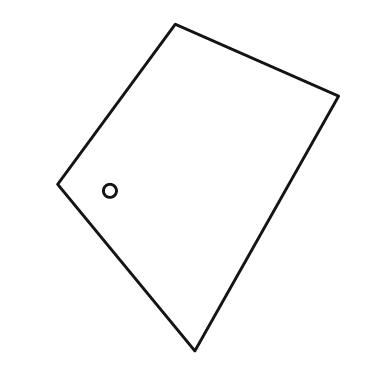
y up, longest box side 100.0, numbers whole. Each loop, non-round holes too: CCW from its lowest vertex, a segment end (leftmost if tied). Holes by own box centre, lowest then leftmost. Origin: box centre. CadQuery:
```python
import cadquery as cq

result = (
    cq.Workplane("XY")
    .moveTo(-1.0, -50.0)
    .lineTo(43.0, 28.0)
    .lineTo(-7.0, 50.0)
    .lineTo(-43.0, 1.0)
    .close()
    .moveTo(-27.0, -1.0)
    .circle(2.0)
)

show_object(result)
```